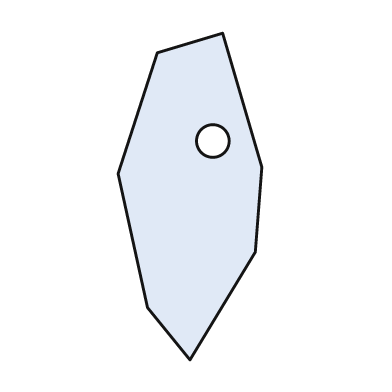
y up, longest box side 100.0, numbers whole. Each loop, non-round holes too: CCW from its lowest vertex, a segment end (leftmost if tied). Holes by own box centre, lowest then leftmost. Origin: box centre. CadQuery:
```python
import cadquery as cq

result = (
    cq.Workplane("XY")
    .moveTo(0.0, -50.0)
    .lineTo(20.0, -17.0)
    .lineTo(22.0, 9.0)
    .lineTo(10.0, 50.0)
    .lineTo(-10.0, 44.0)
    .lineTo(-22.0, 7.0)
    .lineTo(-13.0, -34.0)
    .close()
    .moveTo(7.0, 17.0)
    .circle(5.0)
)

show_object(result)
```